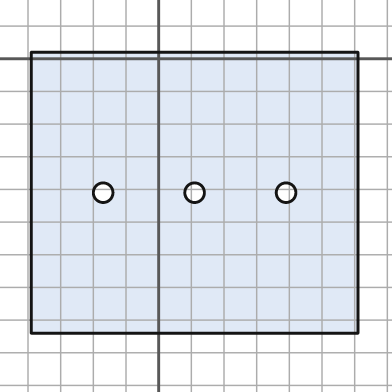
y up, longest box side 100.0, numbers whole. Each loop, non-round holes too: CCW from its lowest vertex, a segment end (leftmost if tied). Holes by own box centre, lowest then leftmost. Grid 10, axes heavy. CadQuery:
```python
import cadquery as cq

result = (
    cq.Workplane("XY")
    .moveTo(-39.0, -84.0)
    .lineTo(61.0, -84.0)
    .lineTo(61.0, 2.0)
    .lineTo(-39.0, 2.0)
    .close()
    .moveTo(-17.0, -41.0)
    .circle(3.0)
    .moveTo(11.0, -41.0)
    .circle(3.0)
    .moveTo(39.0, -41.0)
    .circle(3.0)
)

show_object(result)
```